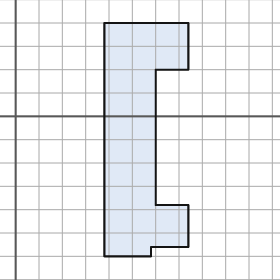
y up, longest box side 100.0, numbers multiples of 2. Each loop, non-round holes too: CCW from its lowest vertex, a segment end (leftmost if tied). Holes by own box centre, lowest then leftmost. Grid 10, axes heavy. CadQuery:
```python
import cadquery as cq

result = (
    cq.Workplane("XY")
    .moveTo(38.0, -60.0)
    .lineTo(58.0, -60.0)
    .lineTo(58.0, -56.0)
    .lineTo(74.0, -56.0)
    .lineTo(74.0, -38.0)
    .lineTo(60.0, -38.0)
    .lineTo(60.0, 20.0)
    .lineTo(74.0, 20.0)
    .lineTo(74.0, 40.0)
    .lineTo(38.0, 40.0)
    .close()
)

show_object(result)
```